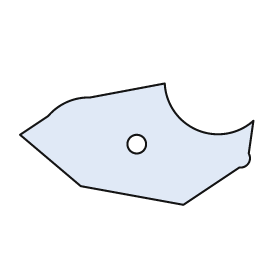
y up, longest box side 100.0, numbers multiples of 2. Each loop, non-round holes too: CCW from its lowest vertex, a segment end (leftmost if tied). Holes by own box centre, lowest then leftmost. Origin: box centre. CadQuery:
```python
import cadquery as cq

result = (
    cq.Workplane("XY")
    .moveTo(20.0, -26.0)
    .lineTo(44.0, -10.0)
    .threePointArc((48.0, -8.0), (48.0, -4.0))
    .lineTo(50.0, 10.0)
    .threePointArc((26.0, 6.0), (12.0, 26.0))
    .lineTo(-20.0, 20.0)
    .threePointArc((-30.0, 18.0), (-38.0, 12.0))
    .lineTo(-50.0, 4.0)
    .lineTo(-24.0, -18.0)
    .close()
    .moveTo(0.0, 0.0)
    .circle(4.0)
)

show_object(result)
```